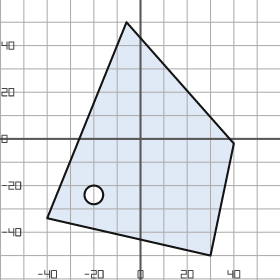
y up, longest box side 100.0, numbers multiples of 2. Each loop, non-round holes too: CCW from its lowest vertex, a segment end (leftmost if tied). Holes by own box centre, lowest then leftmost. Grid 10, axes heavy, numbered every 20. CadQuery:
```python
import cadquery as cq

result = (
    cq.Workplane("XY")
    .moveTo(30.0, -50.0)
    .lineTo(40.0, -2.0)
    .lineTo(-6.0, 50.0)
    .lineTo(-40.0, -34.0)
    .close()
    .moveTo(-20.0, -24.0)
    .circle(4.0)
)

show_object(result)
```